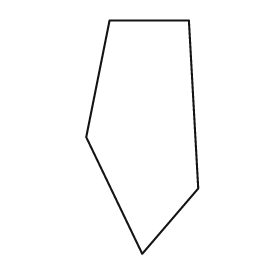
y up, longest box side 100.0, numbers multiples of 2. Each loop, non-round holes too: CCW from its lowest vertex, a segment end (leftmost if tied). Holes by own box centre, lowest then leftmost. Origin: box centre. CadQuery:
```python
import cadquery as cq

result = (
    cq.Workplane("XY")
    .moveTo(0.0, -50.0)
    .lineTo(24.0, -22.0)
    .lineTo(20.0, 50.0)
    .lineTo(-14.0, 50.0)
    .lineTo(-24.0, 0.0)
    .close()
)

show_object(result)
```